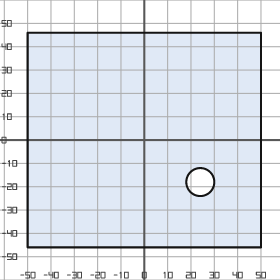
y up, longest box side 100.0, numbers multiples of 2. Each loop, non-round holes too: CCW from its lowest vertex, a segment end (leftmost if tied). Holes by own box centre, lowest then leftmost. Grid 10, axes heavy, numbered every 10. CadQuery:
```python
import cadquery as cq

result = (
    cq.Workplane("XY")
    .moveTo(-50.0, -46.0)
    .lineTo(50.0, -46.0)
    .lineTo(50.0, 46.0)
    .lineTo(-50.0, 46.0)
    .close()
    .moveTo(24.0, -18.0)
    .circle(6.0)
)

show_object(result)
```